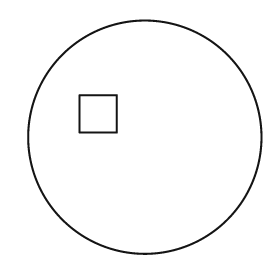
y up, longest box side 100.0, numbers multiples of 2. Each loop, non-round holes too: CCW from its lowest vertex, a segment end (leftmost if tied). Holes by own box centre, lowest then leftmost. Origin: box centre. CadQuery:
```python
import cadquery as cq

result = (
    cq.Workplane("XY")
    .moveTo(0.0, 0.0)
    .circle(50.0)
    .moveTo(-28.0, 2.0)
    .lineTo(-12.0, 2.0)
    .lineTo(-12.0, 18.0)
    .lineTo(-28.0, 18.0)
    .close()
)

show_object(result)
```